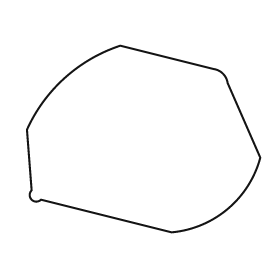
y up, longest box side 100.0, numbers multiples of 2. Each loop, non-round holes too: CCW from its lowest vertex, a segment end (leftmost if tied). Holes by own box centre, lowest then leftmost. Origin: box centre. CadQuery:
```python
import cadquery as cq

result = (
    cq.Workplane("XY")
    .moveTo(12.0, -40.0)
    .threePointArc((36.0, -30.0), (50.0, -8.0))
    .lineTo(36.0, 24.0)
    .threePointArc((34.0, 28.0), (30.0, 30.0))
    .lineTo(-10.0, 40.0)
    .threePointArc((-34.0, 26.0), (-50.0, 4.0))
    .lineTo(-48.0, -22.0)
    .threePointArc((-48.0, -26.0), (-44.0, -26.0))
    .close()
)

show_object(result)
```